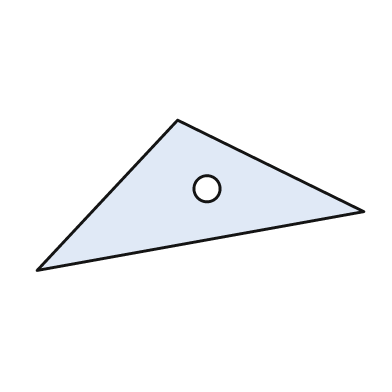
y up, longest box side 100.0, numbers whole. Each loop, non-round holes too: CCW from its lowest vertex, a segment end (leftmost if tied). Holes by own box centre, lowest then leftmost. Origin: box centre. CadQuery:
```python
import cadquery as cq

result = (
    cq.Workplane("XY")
    .moveTo(-50.0, -23.0)
    .lineTo(50.0, -5.0)
    .lineTo(-7.0, 23.0)
    .close()
    .moveTo(2.0, 2.0)
    .circle(4.0)
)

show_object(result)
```